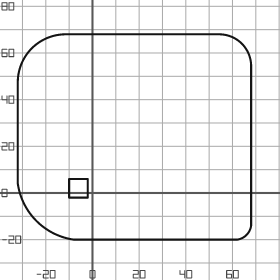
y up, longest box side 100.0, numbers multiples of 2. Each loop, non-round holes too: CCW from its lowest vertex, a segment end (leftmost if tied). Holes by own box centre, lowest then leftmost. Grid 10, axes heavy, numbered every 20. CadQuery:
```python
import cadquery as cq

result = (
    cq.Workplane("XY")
    .moveTo(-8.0, -20.0)
    .lineTo(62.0, -20.0)
    .threePointArc((66.0, -18.0), (68.0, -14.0))
    .lineTo(68.0, 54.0)
    .threePointArc((64.0, 64.0), (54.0, 68.0))
    .lineTo(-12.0, 68.0)
    .threePointArc((-26.0, 62.0), (-32.0, 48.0))
    .lineTo(-32.0, 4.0)
    .threePointArc((-24.0, -12.0), (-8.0, -20.0))
    .close()
    .moveTo(-10.0, -2.0)
    .lineTo(-2.0, -2.0)
    .lineTo(-2.0, 6.0)
    .lineTo(-10.0, 6.0)
    .close()
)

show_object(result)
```